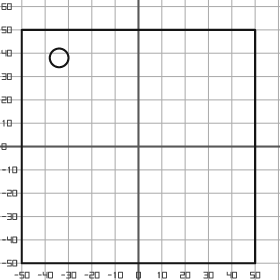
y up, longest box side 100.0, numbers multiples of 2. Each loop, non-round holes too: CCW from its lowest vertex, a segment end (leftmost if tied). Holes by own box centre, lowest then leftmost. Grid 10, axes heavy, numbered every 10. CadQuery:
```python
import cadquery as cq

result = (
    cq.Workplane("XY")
    .moveTo(-50.0, -50.0)
    .lineTo(50.0, -50.0)
    .lineTo(50.0, 50.0)
    .lineTo(-50.0, 50.0)
    .close()
    .moveTo(-34.0, 38.0)
    .circle(4.0)
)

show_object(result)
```